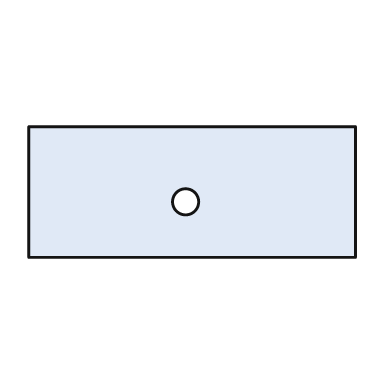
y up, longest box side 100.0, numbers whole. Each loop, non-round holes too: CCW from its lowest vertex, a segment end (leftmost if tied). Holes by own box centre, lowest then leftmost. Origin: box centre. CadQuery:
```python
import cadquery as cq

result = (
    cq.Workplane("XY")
    .moveTo(-50.0, -20.0)
    .lineTo(50.0, -20.0)
    .lineTo(50.0, 20.0)
    .lineTo(-50.0, 20.0)
    .close()
    .moveTo(-2.0, -3.0)
    .circle(4.0)
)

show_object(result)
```